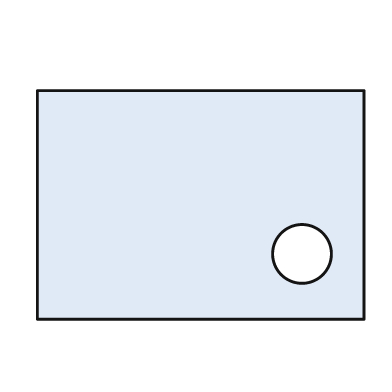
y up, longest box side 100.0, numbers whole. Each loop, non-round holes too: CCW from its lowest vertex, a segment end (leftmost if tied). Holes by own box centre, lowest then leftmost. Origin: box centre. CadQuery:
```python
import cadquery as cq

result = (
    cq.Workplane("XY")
    .moveTo(-50.0, -35.0)
    .lineTo(50.0, -35.0)
    .lineTo(50.0, 35.0)
    .lineTo(-50.0, 35.0)
    .close()
    .moveTo(31.0, -15.0)
    .circle(9.0)
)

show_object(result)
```